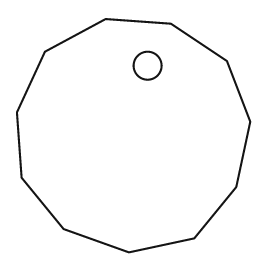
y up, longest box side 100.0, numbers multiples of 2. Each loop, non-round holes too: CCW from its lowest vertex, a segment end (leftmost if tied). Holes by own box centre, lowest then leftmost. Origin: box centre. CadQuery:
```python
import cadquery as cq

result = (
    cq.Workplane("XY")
    .moveTo(-2.0, -50.0)
    .lineTo(26.0, -44.0)
    .lineTo(44.0, -22.0)
    .lineTo(50.0, 6.0)
    .lineTo(40.0, 32.0)
    .lineTo(16.0, 48.0)
    .lineTo(-12.0, 50.0)
    .lineTo(-38.0, 36.0)
    .lineTo(-50.0, 10.0)
    .lineTo(-48.0, -18.0)
    .lineTo(-30.0, -40.0)
    .close()
    .moveTo(6.0, 30.0)
    .circle(6.0)
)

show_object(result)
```